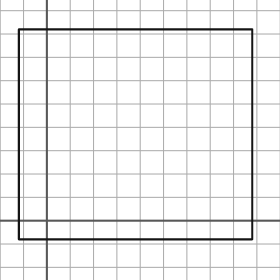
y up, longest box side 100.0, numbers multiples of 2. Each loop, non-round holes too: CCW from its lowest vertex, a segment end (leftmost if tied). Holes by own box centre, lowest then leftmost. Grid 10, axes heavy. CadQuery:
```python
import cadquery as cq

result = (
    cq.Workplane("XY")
    .moveTo(-12.0, -8.0)
    .lineTo(88.0, -8.0)
    .lineTo(88.0, 82.0)
    .lineTo(-12.0, 82.0)
    .close()
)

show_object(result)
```